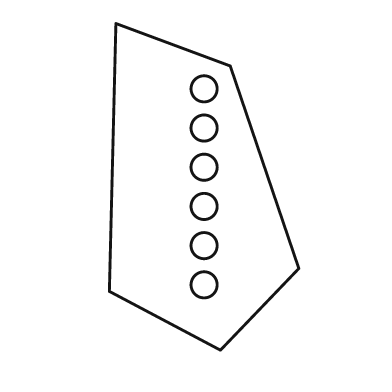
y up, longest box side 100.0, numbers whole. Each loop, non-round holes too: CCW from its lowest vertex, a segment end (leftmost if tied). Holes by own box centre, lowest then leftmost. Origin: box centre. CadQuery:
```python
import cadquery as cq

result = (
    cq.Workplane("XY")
    .moveTo(5.0, -50.0)
    .lineTo(29.0, -25.0)
    .lineTo(8.0, 37.0)
    .lineTo(-27.0, 50.0)
    .lineTo(-29.0, -32.0)
    .close()
    .moveTo(0.0, -30.0)
    .circle(4.0)
    .moveTo(0.0, -18.0)
    .circle(4.0)
    .moveTo(0.0, -6.0)
    .circle(4.0)
    .moveTo(0.0, 6.0)
    .circle(4.0)
    .moveTo(0.0, 18.0)
    .circle(4.0)
    .moveTo(0.0, 30.0)
    .circle(4.0)
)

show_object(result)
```